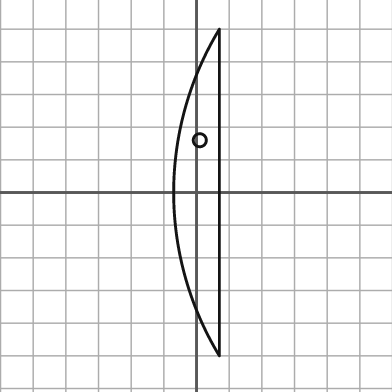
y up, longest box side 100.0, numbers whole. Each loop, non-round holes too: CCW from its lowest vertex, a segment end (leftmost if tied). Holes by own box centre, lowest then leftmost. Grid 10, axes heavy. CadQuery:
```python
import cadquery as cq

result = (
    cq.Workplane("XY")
    .moveTo(7.0, -50.0)
    .lineTo(7.0, 50.0)
    .threePointArc((-7.0, 0.0), (7.0, -50.0))
    .close()
    .moveTo(1.0, 16.0)
    .circle(2.0)
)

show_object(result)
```